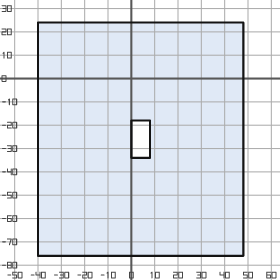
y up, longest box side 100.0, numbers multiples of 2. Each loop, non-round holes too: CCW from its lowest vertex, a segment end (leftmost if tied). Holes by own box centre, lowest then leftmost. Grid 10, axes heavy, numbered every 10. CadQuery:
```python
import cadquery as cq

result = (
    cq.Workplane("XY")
    .moveTo(-40.0, -76.0)
    .lineTo(48.0, -76.0)
    .lineTo(48.0, 24.0)
    .lineTo(-40.0, 24.0)
    .close()
    .moveTo(0.0, -34.0)
    .lineTo(8.0, -34.0)
    .lineTo(8.0, -18.0)
    .lineTo(0.0, -18.0)
    .close()
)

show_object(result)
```